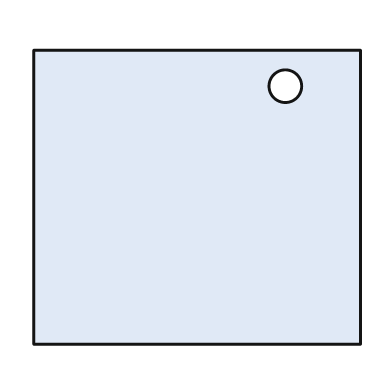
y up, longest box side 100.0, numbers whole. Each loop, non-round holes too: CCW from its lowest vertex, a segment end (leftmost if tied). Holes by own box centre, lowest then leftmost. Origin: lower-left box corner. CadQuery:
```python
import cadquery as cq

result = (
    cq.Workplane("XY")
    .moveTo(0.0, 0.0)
    .lineTo(100.0, 0.0)
    .lineTo(100.0, 90.0)
    .lineTo(0.0, 90.0)
    .close()
    .moveTo(77.0, 79.0)
    .circle(5.0)
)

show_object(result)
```